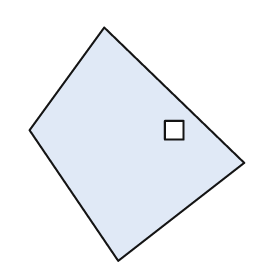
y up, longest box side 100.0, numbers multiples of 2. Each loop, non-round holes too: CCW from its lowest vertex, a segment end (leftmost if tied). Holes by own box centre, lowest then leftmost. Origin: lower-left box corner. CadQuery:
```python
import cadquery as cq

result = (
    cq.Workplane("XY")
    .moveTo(38.0, 0.0)
    .lineTo(92.0, 42.0)
    .lineTo(32.0, 100.0)
    .lineTo(0.0, 56.0)
    .close()
    .moveTo(58.0, 52.0)
    .lineTo(66.0, 52.0)
    .lineTo(66.0, 60.0)
    .lineTo(58.0, 60.0)
    .close()
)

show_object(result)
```